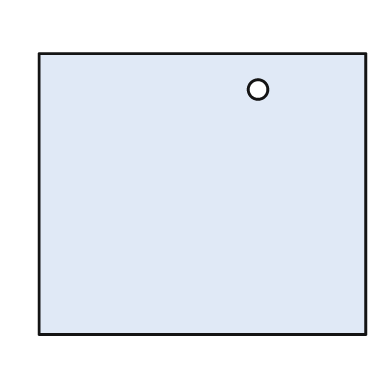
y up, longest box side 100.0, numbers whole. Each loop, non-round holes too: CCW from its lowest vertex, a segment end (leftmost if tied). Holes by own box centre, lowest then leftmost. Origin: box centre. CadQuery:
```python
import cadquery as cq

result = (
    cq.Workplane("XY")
    .moveTo(-50.0, -43.0)
    .lineTo(50.0, -43.0)
    .lineTo(50.0, 43.0)
    .lineTo(-50.0, 43.0)
    .close()
    .moveTo(17.0, 32.0)
    .circle(3.0)
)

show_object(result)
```